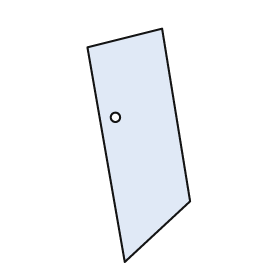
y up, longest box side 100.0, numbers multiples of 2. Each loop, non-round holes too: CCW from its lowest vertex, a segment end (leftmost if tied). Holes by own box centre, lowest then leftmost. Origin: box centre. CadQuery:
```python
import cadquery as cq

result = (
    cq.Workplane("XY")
    .moveTo(-6.0, -50.0)
    .lineTo(22.0, -24.0)
    .lineTo(10.0, 50.0)
    .lineTo(-22.0, 42.0)
    .close()
    .moveTo(-10.0, 12.0)
    .circle(2.0)
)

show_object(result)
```